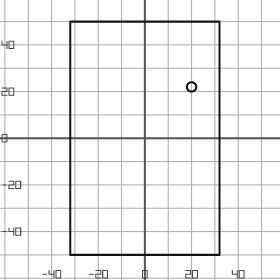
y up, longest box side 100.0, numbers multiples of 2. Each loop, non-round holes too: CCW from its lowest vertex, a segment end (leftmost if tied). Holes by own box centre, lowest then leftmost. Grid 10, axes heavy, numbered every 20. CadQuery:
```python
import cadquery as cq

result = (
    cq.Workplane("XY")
    .moveTo(-32.0, -50.0)
    .lineTo(32.0, -50.0)
    .lineTo(32.0, 50.0)
    .lineTo(-32.0, 50.0)
    .close()
    .moveTo(20.0, 22.0)
    .circle(2.0)
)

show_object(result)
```